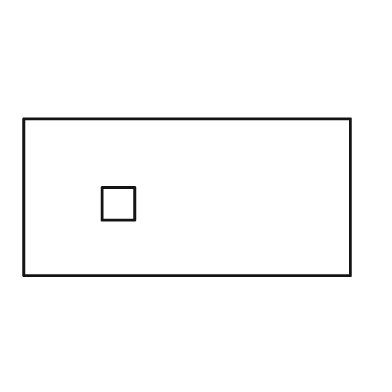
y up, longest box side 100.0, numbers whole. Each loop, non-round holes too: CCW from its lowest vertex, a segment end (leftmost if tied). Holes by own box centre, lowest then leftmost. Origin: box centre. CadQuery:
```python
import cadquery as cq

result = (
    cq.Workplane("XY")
    .moveTo(-50.0, -24.0)
    .lineTo(50.0, -24.0)
    .lineTo(50.0, 24.0)
    .lineTo(-50.0, 24.0)
    .close()
    .moveTo(-26.0, -7.0)
    .lineTo(-16.0, -7.0)
    .lineTo(-16.0, 3.0)
    .lineTo(-26.0, 3.0)
    .close()
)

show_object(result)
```